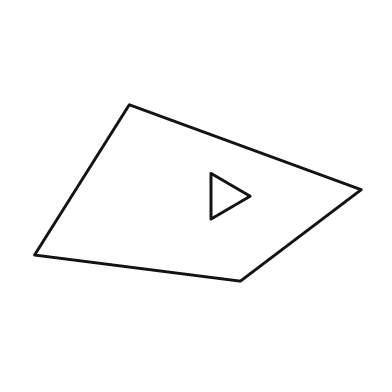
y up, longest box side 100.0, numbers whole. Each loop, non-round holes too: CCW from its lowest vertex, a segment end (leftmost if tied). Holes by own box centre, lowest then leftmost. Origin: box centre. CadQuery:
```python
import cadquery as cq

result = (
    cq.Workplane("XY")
    .moveTo(13.0, -27.0)
    .lineTo(50.0, 1.0)
    .lineTo(-21.0, 27.0)
    .lineTo(-50.0, -19.0)
    .close()
    .moveTo(4.0, -8.0)
    .lineTo(16.0, -1.0)
    .lineTo(4.0, 6.0)
    .close()
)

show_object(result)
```